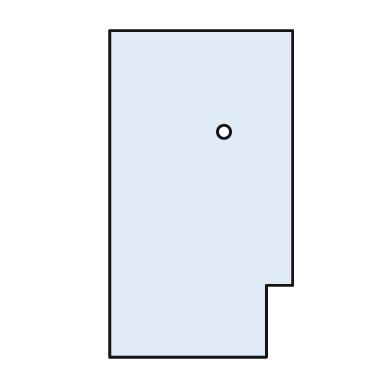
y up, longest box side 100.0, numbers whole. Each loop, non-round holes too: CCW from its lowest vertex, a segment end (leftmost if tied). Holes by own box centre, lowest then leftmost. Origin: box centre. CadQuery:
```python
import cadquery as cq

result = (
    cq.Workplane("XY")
    .moveTo(-28.0, -50.0)
    .lineTo(20.0, -50.0)
    .lineTo(20.0, -28.0)
    .lineTo(28.0, -28.0)
    .lineTo(28.0, 50.0)
    .lineTo(-28.0, 50.0)
    .close()
    .moveTo(7.0, 19.0)
    .circle(2.0)
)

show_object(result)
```